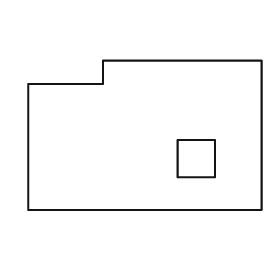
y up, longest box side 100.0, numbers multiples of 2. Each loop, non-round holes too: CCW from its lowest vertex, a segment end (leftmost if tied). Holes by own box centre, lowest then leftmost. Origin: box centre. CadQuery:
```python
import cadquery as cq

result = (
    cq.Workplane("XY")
    .moveTo(-50.0, -32.0)
    .lineTo(50.0, -32.0)
    .lineTo(50.0, 32.0)
    .lineTo(-18.0, 32.0)
    .lineTo(-18.0, 22.0)
    .lineTo(-50.0, 22.0)
    .close()
    .moveTo(14.0, -18.0)
    .lineTo(30.0, -18.0)
    .lineTo(30.0, -2.0)
    .lineTo(14.0, -2.0)
    .close()
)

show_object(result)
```